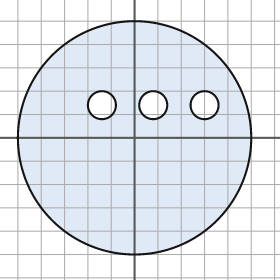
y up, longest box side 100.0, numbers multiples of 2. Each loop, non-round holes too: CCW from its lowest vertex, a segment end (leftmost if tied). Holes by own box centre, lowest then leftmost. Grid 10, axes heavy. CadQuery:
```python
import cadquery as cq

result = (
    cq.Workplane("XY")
    .moveTo(0.0, 0.0)
    .circle(50.0)
    .moveTo(-14.0, 14.0)
    .circle(6.0)
    .moveTo(8.0, 14.0)
    .circle(6.0)
    .moveTo(30.0, 14.0)
    .circle(6.0)
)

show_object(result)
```